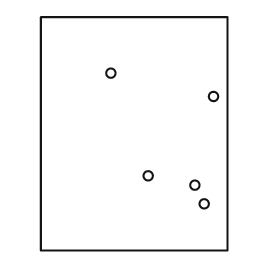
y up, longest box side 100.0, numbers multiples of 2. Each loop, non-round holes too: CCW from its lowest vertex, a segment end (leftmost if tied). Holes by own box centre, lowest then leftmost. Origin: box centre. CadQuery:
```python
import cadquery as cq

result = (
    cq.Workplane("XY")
    .moveTo(-40.0, -50.0)
    .lineTo(40.0, -50.0)
    .lineTo(40.0, 50.0)
    .lineTo(-40.0, 50.0)
    .close()
    .moveTo(30.0, -30.0)
    .circle(2.0)
    .moveTo(26.0, -22.0)
    .circle(2.0)
    .moveTo(6.0, -18.0)
    .circle(2.0)
    .moveTo(34.0, 16.0)
    .circle(2.0)
    .moveTo(-10.0, 26.0)
    .circle(2.0)
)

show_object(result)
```